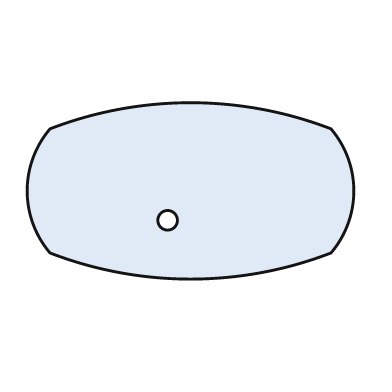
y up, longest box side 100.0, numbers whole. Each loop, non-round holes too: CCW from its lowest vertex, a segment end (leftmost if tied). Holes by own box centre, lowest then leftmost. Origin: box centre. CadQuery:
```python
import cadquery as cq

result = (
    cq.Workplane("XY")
    .moveTo(-43.0, -19.0)
    .threePointArc((0.0, -27.0), (43.0, -19.0))
    .threePointArc((50.0, 0.0), (43.0, 19.0))
    .threePointArc((0.0, 27.0), (-43.0, 19.0))
    .threePointArc((-50.0, 0.0), (-43.0, -19.0))
    .close()
    .moveTo(-7.0, -9.0)
    .circle(3.0)
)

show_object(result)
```